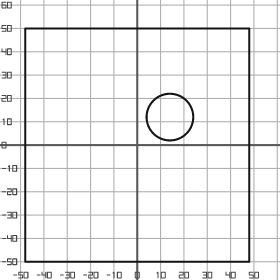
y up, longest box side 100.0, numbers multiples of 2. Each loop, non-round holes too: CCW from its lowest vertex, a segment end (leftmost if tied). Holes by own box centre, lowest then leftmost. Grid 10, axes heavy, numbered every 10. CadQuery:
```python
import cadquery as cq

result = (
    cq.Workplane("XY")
    .moveTo(-48.0, -50.0)
    .lineTo(48.0, -50.0)
    .lineTo(48.0, 50.0)
    .lineTo(-48.0, 50.0)
    .close()
    .moveTo(14.0, 12.0)
    .circle(10.0)
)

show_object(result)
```